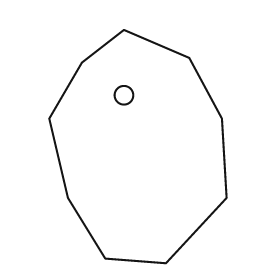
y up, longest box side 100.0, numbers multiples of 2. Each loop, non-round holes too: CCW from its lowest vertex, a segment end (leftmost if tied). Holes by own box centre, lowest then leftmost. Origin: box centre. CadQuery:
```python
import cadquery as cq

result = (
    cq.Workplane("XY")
    .moveTo(12.0, -50.0)
    .lineTo(38.0, -22.0)
    .lineTo(36.0, 12.0)
    .lineTo(22.0, 38.0)
    .lineTo(-6.0, 50.0)
    .lineTo(-24.0, 36.0)
    .lineTo(-38.0, 12.0)
    .lineTo(-30.0, -22.0)
    .lineTo(-14.0, -48.0)
    .close()
    .moveTo(-6.0, 22.0)
    .circle(4.0)
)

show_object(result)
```